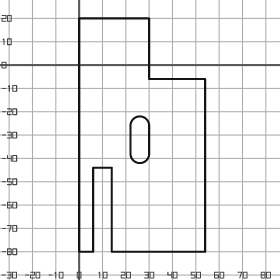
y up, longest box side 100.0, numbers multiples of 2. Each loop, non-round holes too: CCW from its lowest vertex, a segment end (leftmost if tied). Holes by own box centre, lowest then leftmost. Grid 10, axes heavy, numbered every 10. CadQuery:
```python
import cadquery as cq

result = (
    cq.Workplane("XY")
    .moveTo(0.0, -80.0)
    .lineTo(6.0, -80.0)
    .lineTo(6.0, -44.0)
    .lineTo(14.0, -44.0)
    .lineTo(14.0, -80.0)
    .lineTo(54.0, -80.0)
    .lineTo(54.0, -6.0)
    .lineTo(30.0, -6.0)
    .lineTo(30.0, 20.0)
    .lineTo(0.0, 20.0)
    .close()
    .moveTo(22.0, -38.0)
    .threePointArc((26.0, -42.0), (30.0, -38.0))
    .lineTo(30.0, -26.0)
    .threePointArc((26.0, -22.0), (22.0, -26.0))
    .close()
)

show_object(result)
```